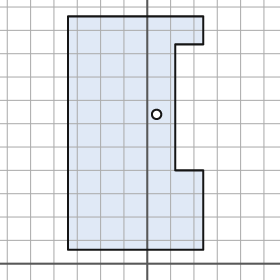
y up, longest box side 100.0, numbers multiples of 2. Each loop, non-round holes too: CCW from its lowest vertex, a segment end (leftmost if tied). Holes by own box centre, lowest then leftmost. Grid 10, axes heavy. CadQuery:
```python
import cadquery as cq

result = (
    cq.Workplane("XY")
    .moveTo(-34.0, 6.0)
    .lineTo(24.0, 6.0)
    .lineTo(24.0, 40.0)
    .lineTo(12.0, 40.0)
    .lineTo(12.0, 94.0)
    .lineTo(24.0, 94.0)
    .lineTo(24.0, 106.0)
    .lineTo(-34.0, 106.0)
    .close()
    .moveTo(4.0, 64.0)
    .circle(2.0)
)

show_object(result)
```